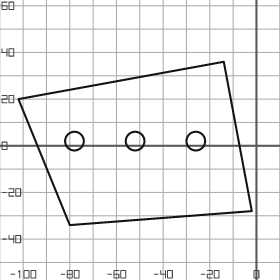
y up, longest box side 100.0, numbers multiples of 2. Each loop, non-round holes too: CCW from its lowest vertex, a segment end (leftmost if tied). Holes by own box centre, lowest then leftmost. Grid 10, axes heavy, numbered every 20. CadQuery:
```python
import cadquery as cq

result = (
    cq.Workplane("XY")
    .moveTo(-80.0, -34.0)
    .lineTo(-2.0, -28.0)
    .lineTo(-14.0, 36.0)
    .lineTo(-102.0, 20.0)
    .close()
    .moveTo(-78.0, 2.0)
    .circle(4.0)
    .moveTo(-52.0, 2.0)
    .circle(4.0)
    .moveTo(-26.0, 2.0)
    .circle(4.0)
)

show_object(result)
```